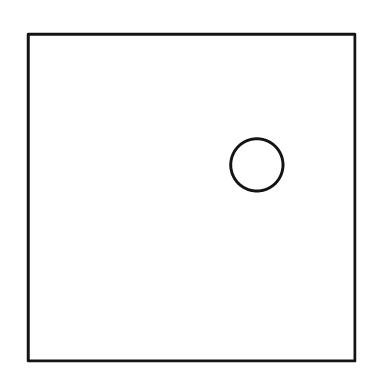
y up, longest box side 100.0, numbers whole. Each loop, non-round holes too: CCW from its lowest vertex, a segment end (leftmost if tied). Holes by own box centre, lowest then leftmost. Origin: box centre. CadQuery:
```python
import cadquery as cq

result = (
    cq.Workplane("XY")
    .moveTo(-50.0, -50.0)
    .lineTo(50.0, -50.0)
    .lineTo(50.0, 50.0)
    .lineTo(-50.0, 50.0)
    .close()
    .moveTo(20.0, 10.0)
    .circle(8.0)
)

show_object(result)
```